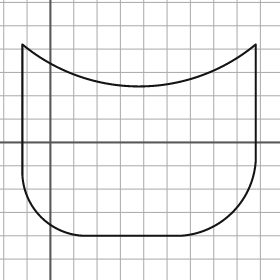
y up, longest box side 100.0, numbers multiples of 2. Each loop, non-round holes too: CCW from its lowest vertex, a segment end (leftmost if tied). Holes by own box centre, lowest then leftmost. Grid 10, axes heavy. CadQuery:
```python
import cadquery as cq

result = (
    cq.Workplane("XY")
    .moveTo(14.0, -40.0)
    .lineTo(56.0, -40.0)
    .threePointArc((78.0, -30.0), (88.0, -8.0))
    .lineTo(88.0, 42.0)
    .threePointArc((38.0, 24.0), (-12.0, 42.0))
    .lineTo(-12.0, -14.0)
    .threePointArc((-4.0, -32.0), (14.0, -40.0))
    .close()
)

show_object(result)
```